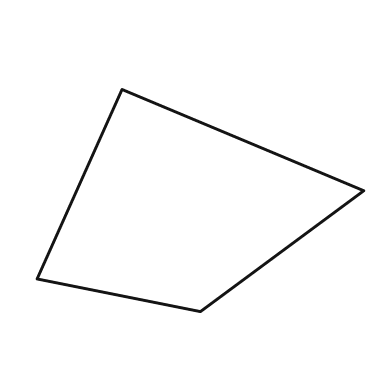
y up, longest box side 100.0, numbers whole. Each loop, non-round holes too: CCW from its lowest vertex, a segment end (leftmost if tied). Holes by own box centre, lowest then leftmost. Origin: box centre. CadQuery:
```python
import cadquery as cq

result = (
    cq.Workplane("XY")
    .moveTo(0.0, -34.0)
    .lineTo(50.0, 3.0)
    .lineTo(-24.0, 34.0)
    .lineTo(-50.0, -24.0)
    .close()
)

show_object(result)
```